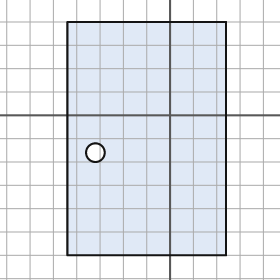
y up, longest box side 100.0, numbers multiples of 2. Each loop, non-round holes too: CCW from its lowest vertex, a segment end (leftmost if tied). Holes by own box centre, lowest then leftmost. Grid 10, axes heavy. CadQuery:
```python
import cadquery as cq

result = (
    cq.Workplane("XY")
    .moveTo(-44.0, -60.0)
    .lineTo(24.0, -60.0)
    .lineTo(24.0, 40.0)
    .lineTo(-44.0, 40.0)
    .close()
    .moveTo(-32.0, -16.0)
    .circle(4.0)
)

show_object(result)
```